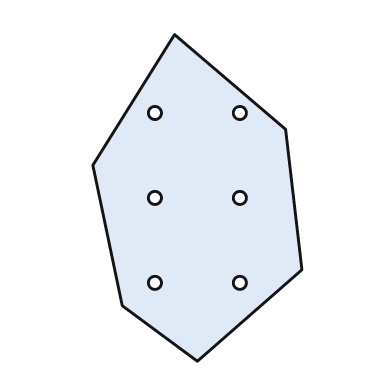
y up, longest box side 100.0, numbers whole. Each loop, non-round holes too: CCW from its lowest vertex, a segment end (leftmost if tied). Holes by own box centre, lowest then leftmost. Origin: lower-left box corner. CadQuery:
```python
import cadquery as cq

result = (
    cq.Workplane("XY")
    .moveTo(32.0, 0.0)
    .lineTo(64.0, 28.0)
    .lineTo(59.0, 71.0)
    .lineTo(25.0, 100.0)
    .lineTo(0.0, 60.0)
    .lineTo(9.0, 17.0)
    .close()
    .moveTo(19.0, 24.0)
    .circle(2.0)
    .moveTo(45.0, 24.0)
    .circle(2.0)
    .moveTo(19.0, 50.0)
    .circle(2.0)
    .moveTo(45.0, 50.0)
    .circle(2.0)
    .moveTo(19.0, 76.0)
    .circle(2.0)
    .moveTo(45.0, 76.0)
    .circle(2.0)
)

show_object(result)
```